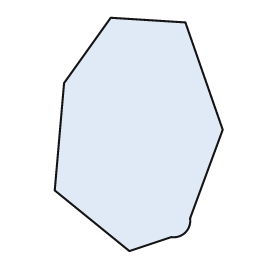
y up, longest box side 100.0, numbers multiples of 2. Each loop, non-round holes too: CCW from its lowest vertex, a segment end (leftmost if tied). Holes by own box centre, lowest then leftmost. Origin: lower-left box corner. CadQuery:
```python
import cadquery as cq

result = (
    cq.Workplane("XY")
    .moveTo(32.0, 0.0)
    .lineTo(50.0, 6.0)
    .threePointArc((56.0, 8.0), (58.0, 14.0))
    .lineTo(72.0, 52.0)
    .lineTo(56.0, 98.0)
    .lineTo(24.0, 100.0)
    .lineTo(4.0, 72.0)
    .lineTo(0.0, 26.0)
    .close()
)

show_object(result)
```